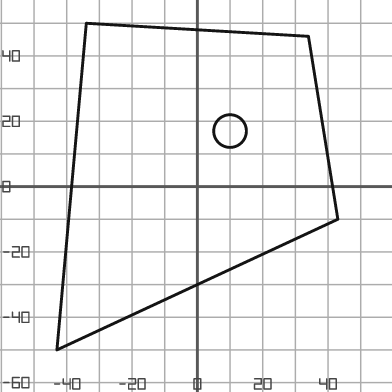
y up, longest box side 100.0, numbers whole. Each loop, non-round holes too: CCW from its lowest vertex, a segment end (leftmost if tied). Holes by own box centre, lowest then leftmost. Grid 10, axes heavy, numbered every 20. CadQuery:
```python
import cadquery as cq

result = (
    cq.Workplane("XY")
    .moveTo(-43.0, -50.0)
    .lineTo(43.0, -10.0)
    .lineTo(34.0, 46.0)
    .lineTo(-34.0, 50.0)
    .close()
    .moveTo(10.0, 17.0)
    .circle(5.0)
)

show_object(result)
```